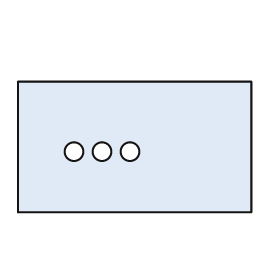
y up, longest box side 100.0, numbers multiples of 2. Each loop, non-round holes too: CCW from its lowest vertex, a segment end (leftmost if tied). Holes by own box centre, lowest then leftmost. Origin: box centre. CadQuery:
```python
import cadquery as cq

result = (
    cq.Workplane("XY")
    .moveTo(-50.0, -28.0)
    .lineTo(50.0, -28.0)
    .lineTo(50.0, 28.0)
    .lineTo(-50.0, 28.0)
    .close()
    .moveTo(-26.0, -2.0)
    .circle(4.0)
    .moveTo(-14.0, -2.0)
    .circle(4.0)
    .moveTo(-2.0, -2.0)
    .circle(4.0)
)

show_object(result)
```